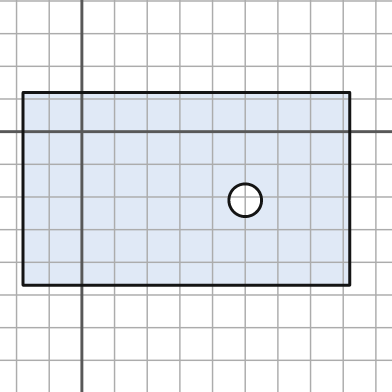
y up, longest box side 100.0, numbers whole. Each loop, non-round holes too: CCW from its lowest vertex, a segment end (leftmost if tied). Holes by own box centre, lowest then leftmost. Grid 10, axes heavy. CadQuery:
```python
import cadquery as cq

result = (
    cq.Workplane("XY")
    .moveTo(-18.0, -47.0)
    .lineTo(82.0, -47.0)
    .lineTo(82.0, 12.0)
    .lineTo(-18.0, 12.0)
    .close()
    .moveTo(50.0, -21.0)
    .circle(5.0)
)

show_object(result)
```